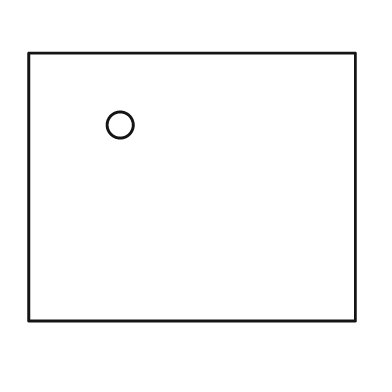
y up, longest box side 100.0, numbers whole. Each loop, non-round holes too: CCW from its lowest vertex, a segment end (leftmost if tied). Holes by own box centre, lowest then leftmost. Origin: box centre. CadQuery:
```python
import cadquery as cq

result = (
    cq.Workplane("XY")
    .moveTo(-50.0, -41.0)
    .lineTo(50.0, -41.0)
    .lineTo(50.0, 41.0)
    .lineTo(-50.0, 41.0)
    .close()
    .moveTo(-22.0, 19.0)
    .circle(4.0)
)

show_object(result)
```